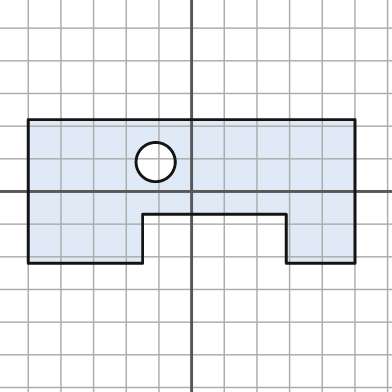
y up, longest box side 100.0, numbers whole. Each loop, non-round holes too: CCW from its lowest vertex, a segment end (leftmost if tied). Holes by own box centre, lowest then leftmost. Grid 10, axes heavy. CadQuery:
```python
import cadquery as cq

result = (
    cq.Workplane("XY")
    .moveTo(-50.0, -22.0)
    .lineTo(-15.0, -22.0)
    .lineTo(-15.0, -7.0)
    .lineTo(29.0, -7.0)
    .lineTo(29.0, -22.0)
    .lineTo(50.0, -22.0)
    .lineTo(50.0, 22.0)
    .lineTo(-50.0, 22.0)
    .close()
    .moveTo(-11.0, 9.0)
    .circle(6.0)
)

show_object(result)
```